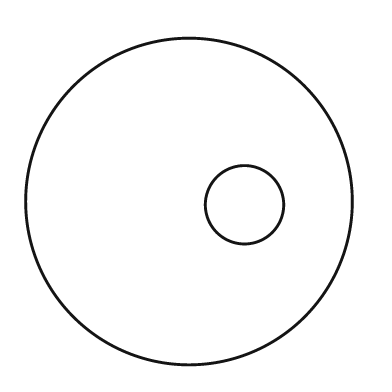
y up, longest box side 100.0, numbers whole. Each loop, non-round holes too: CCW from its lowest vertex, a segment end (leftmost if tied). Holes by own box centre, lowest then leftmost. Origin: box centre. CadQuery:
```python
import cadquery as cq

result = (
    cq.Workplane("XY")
    .moveTo(0.0, 0.0)
    .circle(50.0)
    .moveTo(17.0, -1.0)
    .circle(12.0)
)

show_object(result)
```